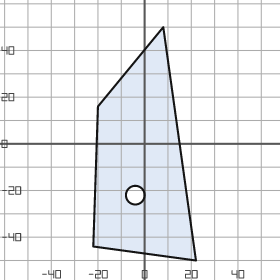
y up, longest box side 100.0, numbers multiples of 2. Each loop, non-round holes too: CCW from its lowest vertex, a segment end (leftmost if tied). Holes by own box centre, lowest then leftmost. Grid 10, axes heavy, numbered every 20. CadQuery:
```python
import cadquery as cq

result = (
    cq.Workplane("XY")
    .moveTo(22.0, -50.0)
    .lineTo(8.0, 50.0)
    .lineTo(-20.0, 16.0)
    .lineTo(-22.0, -44.0)
    .close()
    .moveTo(-4.0, -22.0)
    .circle(4.0)
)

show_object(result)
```